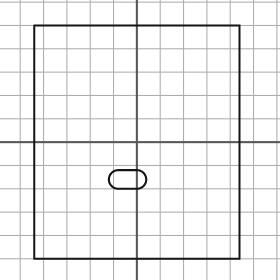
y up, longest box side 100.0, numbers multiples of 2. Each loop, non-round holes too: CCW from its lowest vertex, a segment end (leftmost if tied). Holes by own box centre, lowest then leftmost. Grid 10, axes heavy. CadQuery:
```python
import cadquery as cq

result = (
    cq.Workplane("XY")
    .moveTo(-44.0, -50.0)
    .lineTo(44.0, -50.0)
    .lineTo(44.0, 50.0)
    .lineTo(-44.0, 50.0)
    .close()
    .moveTo(-8.0, -20.0)
    .lineTo(0.0, -20.0)
    .threePointArc((4.0, -16.0), (0.0, -12.0))
    .lineTo(-8.0, -12.0)
    .threePointArc((-12.0, -16.0), (-8.0, -20.0))
    .close()
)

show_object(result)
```